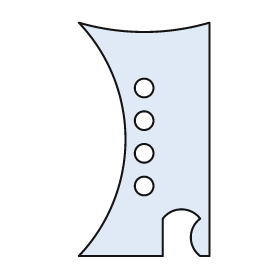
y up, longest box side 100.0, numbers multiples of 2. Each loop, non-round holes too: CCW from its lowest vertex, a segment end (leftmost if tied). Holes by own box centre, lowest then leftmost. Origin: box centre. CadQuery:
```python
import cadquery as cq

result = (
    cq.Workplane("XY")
    .moveTo(-28.0, -50.0)
    .lineTo(8.0, -50.0)
    .lineTo(8.0, -34.0)
    .threePointArc((16.0, -30.0), (24.0, -34.0))
    .threePointArc((20.0, -42.0), (24.0, -50.0))
    .lineTo(28.0, -50.0)
    .lineTo(28.0, 50.0)
    .threePointArc((0.0, 46.0), (-28.0, 50.0))
    .threePointArc((-8.0, 0.0), (-28.0, -50.0))
    .close()
    .moveTo(0.0, -20.0)
    .circle(4.0)
    .moveTo(0.0, -6.0)
    .circle(4.0)
    .moveTo(0.0, 8.0)
    .circle(4.0)
    .moveTo(0.0, 22.0)
    .circle(4.0)
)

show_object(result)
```